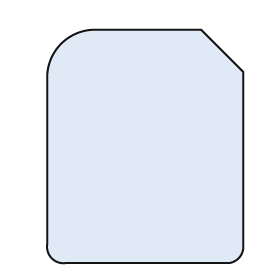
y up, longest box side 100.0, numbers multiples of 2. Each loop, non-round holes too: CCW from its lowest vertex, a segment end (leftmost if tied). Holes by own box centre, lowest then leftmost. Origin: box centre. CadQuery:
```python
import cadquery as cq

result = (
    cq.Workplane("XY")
    .moveTo(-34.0, -50.0)
    .lineTo(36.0, -50.0)
    .threePointArc((40.0, -48.0), (42.0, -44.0))
    .lineTo(42.0, 32.0)
    .lineTo(24.0, 50.0)
    .lineTo(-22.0, 50.0)
    .threePointArc((-36.0, 44.0), (-42.0, 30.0))
    .lineTo(-42.0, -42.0)
    .threePointArc((-40.0, -48.0), (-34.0, -50.0))
    .close()
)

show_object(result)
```